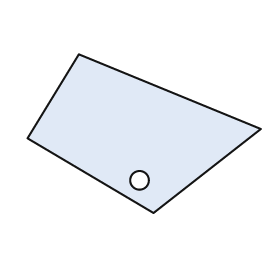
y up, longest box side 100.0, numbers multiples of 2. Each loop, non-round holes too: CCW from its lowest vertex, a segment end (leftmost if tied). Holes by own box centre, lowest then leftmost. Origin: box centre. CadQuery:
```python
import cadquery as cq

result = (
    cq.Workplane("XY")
    .moveTo(4.0, -34.0)
    .lineTo(50.0, 2.0)
    .lineTo(-28.0, 34.0)
    .lineTo(-50.0, -2.0)
    .close()
    .moveTo(-2.0, -20.0)
    .circle(4.0)
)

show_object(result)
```